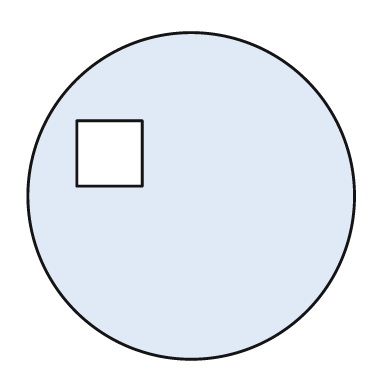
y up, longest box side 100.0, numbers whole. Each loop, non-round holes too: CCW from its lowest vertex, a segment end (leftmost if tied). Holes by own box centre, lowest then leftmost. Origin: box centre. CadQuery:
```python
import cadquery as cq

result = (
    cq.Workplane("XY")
    .moveTo(0.0, 0.0)
    .circle(50.0)
    .moveTo(-35.0, 3.0)
    .lineTo(-15.0, 3.0)
    .lineTo(-15.0, 23.0)
    .lineTo(-35.0, 23.0)
    .close()
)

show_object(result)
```